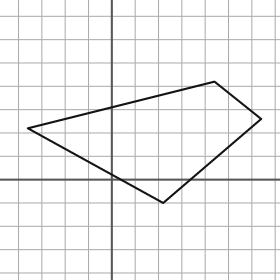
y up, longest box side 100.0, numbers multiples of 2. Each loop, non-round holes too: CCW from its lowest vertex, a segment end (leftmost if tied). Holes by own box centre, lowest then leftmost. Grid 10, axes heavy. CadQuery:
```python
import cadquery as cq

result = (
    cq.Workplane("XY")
    .moveTo(22.0, -10.0)
    .lineTo(64.0, 26.0)
    .lineTo(44.0, 42.0)
    .lineTo(-36.0, 22.0)
    .close()
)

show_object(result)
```